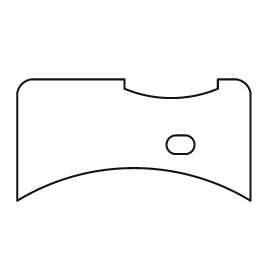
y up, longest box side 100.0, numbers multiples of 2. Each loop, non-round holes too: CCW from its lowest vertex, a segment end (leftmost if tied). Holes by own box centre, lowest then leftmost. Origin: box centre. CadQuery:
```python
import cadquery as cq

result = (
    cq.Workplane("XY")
    .moveTo(-50.0, -26.0)
    .threePointArc((0.0, -12.0), (50.0, -26.0))
    .lineTo(50.0, 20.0)
    .threePointArc((48.0, 24.0), (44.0, 26.0))
    .lineTo(36.0, 26.0)
    .lineTo(36.0, 22.0)
    .threePointArc((16.0, 18.0), (-4.0, 22.0))
    .lineTo(-4.0, 26.0)
    .lineTo(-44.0, 26.0)
    .threePointArc((-48.0, 24.0), (-50.0, 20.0))
    .close()
    .moveTo(18.0, -6.0)
    .lineTo(22.0, -6.0)
    .threePointArc((26.0, -2.0), (22.0, 2.0))
    .lineTo(18.0, 2.0)
    .threePointArc((14.0, -2.0), (18.0, -6.0))
    .close()
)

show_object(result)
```